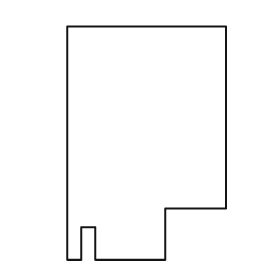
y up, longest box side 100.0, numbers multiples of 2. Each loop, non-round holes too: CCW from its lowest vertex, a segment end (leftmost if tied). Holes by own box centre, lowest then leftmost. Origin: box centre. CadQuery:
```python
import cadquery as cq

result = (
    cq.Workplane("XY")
    .moveTo(-34.0, -50.0)
    .lineTo(-28.0, -50.0)
    .lineTo(-28.0, -36.0)
    .lineTo(-22.0, -36.0)
    .lineTo(-22.0, -50.0)
    .lineTo(8.0, -50.0)
    .lineTo(8.0, -28.0)
    .lineTo(34.0, -28.0)
    .lineTo(34.0, 50.0)
    .lineTo(-34.0, 50.0)
    .close()
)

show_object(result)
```